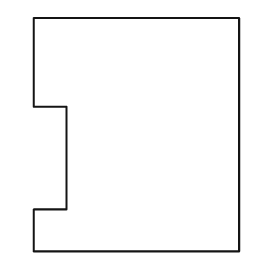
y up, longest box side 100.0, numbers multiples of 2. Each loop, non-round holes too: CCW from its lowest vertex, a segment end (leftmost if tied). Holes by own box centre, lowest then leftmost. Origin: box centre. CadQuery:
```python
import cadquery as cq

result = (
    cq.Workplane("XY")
    .moveTo(-44.0, -50.0)
    .lineTo(44.0, -50.0)
    .lineTo(44.0, 50.0)
    .lineTo(-44.0, 50.0)
    .lineTo(-44.0, 12.0)
    .lineTo(-30.0, 12.0)
    .lineTo(-30.0, -32.0)
    .lineTo(-44.0, -32.0)
    .close()
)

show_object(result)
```